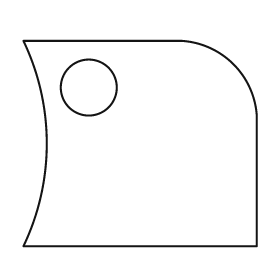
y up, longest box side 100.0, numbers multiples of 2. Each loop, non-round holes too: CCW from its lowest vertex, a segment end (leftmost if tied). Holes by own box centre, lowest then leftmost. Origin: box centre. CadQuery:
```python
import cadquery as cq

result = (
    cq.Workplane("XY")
    .moveTo(-50.0, -44.0)
    .lineTo(50.0, -44.0)
    .lineTo(50.0, 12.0)
    .threePointArc((40.0, 34.0), (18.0, 44.0))
    .lineTo(-50.0, 44.0)
    .threePointArc((-40.0, 0.0), (-50.0, -44.0))
    .close()
    .moveTo(-22.0, 24.0)
    .circle(12.0)
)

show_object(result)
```